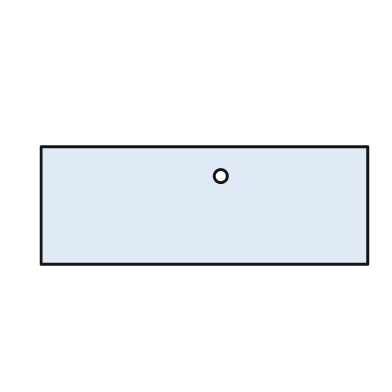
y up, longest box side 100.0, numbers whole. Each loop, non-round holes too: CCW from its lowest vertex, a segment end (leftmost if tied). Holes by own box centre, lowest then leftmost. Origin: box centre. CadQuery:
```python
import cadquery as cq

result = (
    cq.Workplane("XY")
    .moveTo(-50.0, -18.0)
    .lineTo(50.0, -18.0)
    .lineTo(50.0, 18.0)
    .lineTo(-50.0, 18.0)
    .close()
    .moveTo(5.0, 9.0)
    .circle(2.0)
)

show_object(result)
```